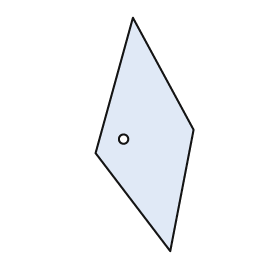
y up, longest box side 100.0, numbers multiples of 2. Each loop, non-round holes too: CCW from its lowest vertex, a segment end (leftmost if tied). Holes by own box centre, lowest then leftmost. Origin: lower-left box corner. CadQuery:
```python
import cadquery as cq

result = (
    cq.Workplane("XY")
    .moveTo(32.0, 0.0)
    .lineTo(42.0, 52.0)
    .lineTo(16.0, 100.0)
    .lineTo(0.0, 42.0)
    .close()
    .moveTo(12.0, 48.0)
    .circle(2.0)
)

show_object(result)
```